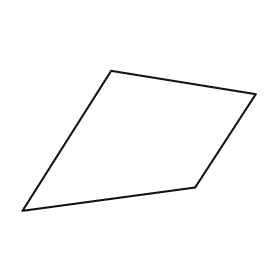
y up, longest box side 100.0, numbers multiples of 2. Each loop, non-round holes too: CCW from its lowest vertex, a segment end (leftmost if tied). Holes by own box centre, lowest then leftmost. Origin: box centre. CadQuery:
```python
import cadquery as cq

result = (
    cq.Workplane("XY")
    .moveTo(-50.0, -30.0)
    .lineTo(24.0, -20.0)
    .lineTo(50.0, 20.0)
    .lineTo(-12.0, 30.0)
    .close()
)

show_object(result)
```